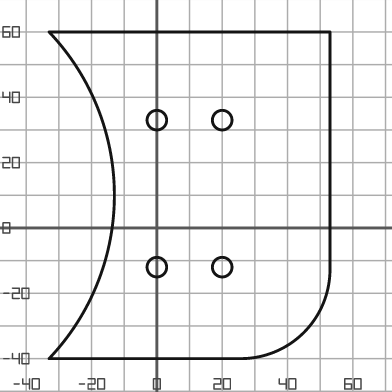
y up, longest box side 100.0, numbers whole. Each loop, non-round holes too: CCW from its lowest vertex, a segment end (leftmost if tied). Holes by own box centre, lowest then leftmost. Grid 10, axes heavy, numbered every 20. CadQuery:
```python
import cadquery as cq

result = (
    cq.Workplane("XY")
    .moveTo(-33.0, -40.0)
    .lineTo(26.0, -40.0)
    .threePointArc((45.0, -32.0), (53.0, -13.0))
    .lineTo(53.0, 60.0)
    .lineTo(-33.0, 60.0)
    .threePointArc((-13.0, 10.0), (-33.0, -40.0))
    .close()
    .moveTo(0.0, -12.0)
    .circle(3.0)
    .moveTo(20.0, -12.0)
    .circle(3.0)
    .moveTo(0.0, 33.0)
    .circle(3.0)
    .moveTo(20.0, 33.0)
    .circle(3.0)
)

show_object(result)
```